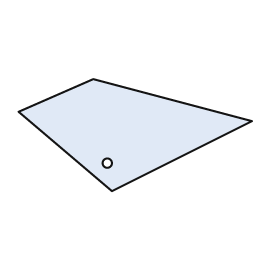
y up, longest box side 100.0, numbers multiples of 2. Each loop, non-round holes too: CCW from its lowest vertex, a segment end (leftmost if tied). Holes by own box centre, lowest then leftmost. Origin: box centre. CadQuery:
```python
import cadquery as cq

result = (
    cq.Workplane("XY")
    .moveTo(-10.0, -24.0)
    .lineTo(50.0, 6.0)
    .lineTo(-18.0, 24.0)
    .lineTo(-50.0, 10.0)
    .close()
    .moveTo(-12.0, -12.0)
    .circle(2.0)
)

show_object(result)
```